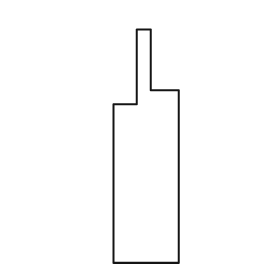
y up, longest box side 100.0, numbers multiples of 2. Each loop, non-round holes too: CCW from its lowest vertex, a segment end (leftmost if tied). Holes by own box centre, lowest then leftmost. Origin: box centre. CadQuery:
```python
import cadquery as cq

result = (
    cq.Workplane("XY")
    .moveTo(-14.0, -50.0)
    .lineTo(14.0, -50.0)
    .lineTo(14.0, 24.0)
    .lineTo(2.0, 24.0)
    .lineTo(2.0, 50.0)
    .lineTo(-4.0, 50.0)
    .lineTo(-4.0, 18.0)
    .lineTo(-14.0, 18.0)
    .close()
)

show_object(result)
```